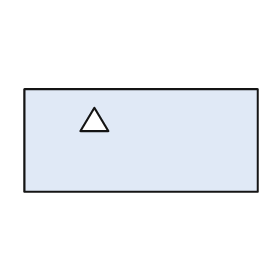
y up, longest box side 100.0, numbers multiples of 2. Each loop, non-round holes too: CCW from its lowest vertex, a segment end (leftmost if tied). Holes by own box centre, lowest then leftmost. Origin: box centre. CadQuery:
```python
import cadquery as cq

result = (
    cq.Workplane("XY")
    .moveTo(-50.0, -22.0)
    .lineTo(50.0, -22.0)
    .lineTo(50.0, 22.0)
    .lineTo(-50.0, 22.0)
    .close()
    .moveTo(-26.0, 4.0)
    .lineTo(-14.0, 4.0)
    .lineTo(-20.0, 14.0)
    .close()
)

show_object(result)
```